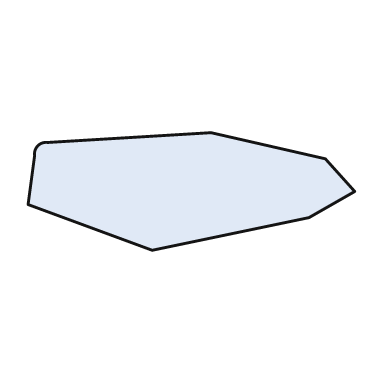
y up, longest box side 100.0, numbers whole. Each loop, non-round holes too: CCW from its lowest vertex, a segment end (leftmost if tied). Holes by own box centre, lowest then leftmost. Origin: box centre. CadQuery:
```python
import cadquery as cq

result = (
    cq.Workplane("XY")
    .moveTo(-12.0, -18.0)
    .lineTo(36.0, -8.0)
    .lineTo(50.0, 0.0)
    .lineTo(41.0, 10.0)
    .lineTo(6.0, 18.0)
    .lineTo(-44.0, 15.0)
    .threePointArc((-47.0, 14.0), (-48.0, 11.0))
    .lineTo(-50.0, -4.0)
    .close()
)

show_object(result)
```